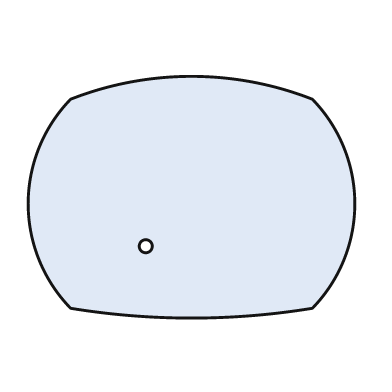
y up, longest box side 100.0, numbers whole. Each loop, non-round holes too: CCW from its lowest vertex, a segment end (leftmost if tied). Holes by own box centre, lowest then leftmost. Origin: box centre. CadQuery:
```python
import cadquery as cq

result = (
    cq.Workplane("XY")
    .moveTo(-37.0, -34.0)
    .threePointArc((0.0, -37.0), (37.0, -34.0))
    .threePointArc((50.0, -2.0), (37.0, 30.0))
    .threePointArc((0.0, 37.0), (-37.0, 30.0))
    .threePointArc((-50.0, -2.0), (-37.0, -34.0))
    .close()
    .moveTo(-14.0, -15.0)
    .circle(2.0)
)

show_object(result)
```